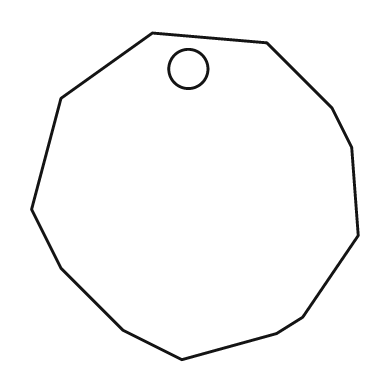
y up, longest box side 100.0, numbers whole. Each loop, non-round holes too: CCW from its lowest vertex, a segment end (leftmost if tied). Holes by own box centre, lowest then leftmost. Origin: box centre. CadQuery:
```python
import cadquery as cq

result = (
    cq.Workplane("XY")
    .moveTo(-4.0, -50.0)
    .lineTo(25.0, -42.0)
    .lineTo(33.0, -37.0)
    .lineTo(50.0, -12.0)
    .lineTo(48.0, 15.0)
    .lineTo(42.0, 27.0)
    .lineTo(22.0, 47.0)
    .lineTo(-13.0, 50.0)
    .lineTo(-41.0, 30.0)
    .lineTo(-50.0, -4.0)
    .lineTo(-41.0, -22.0)
    .lineTo(-22.0, -41.0)
    .close()
    .moveTo(-2.0, 39.0)
    .circle(6.0)
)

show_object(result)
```